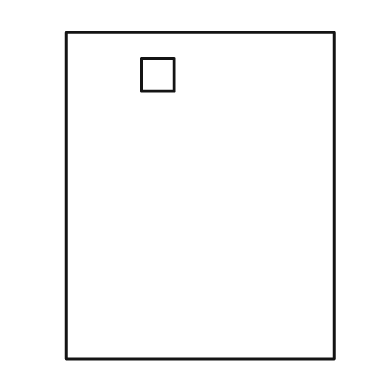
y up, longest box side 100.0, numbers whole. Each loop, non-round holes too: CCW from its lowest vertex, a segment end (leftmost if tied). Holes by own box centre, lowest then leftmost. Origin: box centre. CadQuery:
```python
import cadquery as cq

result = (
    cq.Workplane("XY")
    .moveTo(-41.0, -50.0)
    .lineTo(41.0, -50.0)
    .lineTo(41.0, 50.0)
    .lineTo(-41.0, 50.0)
    .close()
    .moveTo(-18.0, 32.0)
    .lineTo(-8.0, 32.0)
    .lineTo(-8.0, 42.0)
    .lineTo(-18.0, 42.0)
    .close()
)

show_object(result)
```